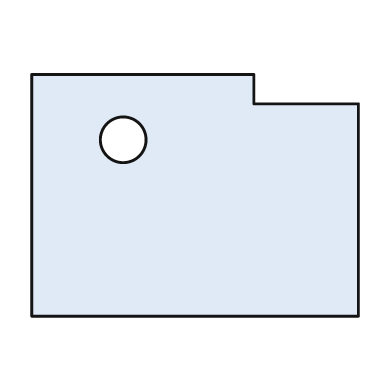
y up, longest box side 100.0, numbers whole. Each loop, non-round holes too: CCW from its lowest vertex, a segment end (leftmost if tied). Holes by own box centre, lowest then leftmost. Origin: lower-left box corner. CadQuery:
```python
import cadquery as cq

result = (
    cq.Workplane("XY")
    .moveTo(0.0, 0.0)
    .lineTo(100.0, 0.0)
    .lineTo(100.0, 65.0)
    .lineTo(68.0, 65.0)
    .lineTo(68.0, 74.0)
    .lineTo(0.0, 74.0)
    .close()
    .moveTo(28.0, 54.0)
    .circle(7.0)
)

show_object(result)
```